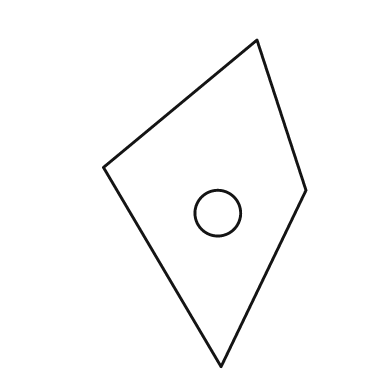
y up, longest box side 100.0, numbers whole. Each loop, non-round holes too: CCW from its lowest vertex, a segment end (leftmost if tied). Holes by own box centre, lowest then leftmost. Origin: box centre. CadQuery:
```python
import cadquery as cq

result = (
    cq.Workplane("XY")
    .moveTo(5.0, -50.0)
    .lineTo(31.0, 4.0)
    .lineTo(16.0, 50.0)
    .lineTo(-31.0, 11.0)
    .close()
    .moveTo(4.0, -3.0)
    .circle(7.0)
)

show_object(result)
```